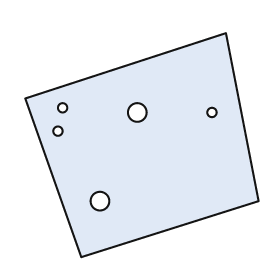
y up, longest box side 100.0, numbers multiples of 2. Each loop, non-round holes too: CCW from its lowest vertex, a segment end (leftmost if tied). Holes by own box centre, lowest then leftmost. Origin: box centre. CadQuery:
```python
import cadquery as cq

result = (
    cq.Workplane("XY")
    .moveTo(-26.0, -48.0)
    .lineTo(50.0, -24.0)
    .lineTo(36.0, 48.0)
    .lineTo(-50.0, 20.0)
    .close()
    .moveTo(-18.0, -24.0)
    .circle(4.0)
    .moveTo(-36.0, 6.0)
    .circle(2.0)
    .moveTo(-2.0, 14.0)
    .circle(4.0)
    .moveTo(30.0, 14.0)
    .circle(2.0)
    .moveTo(-34.0, 16.0)
    .circle(2.0)
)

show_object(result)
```